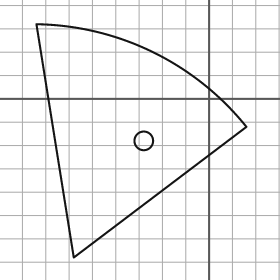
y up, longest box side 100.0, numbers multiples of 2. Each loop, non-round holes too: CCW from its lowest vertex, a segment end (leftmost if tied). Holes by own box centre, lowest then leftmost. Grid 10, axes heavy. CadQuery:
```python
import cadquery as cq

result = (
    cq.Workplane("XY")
    .moveTo(-58.0, -68.0)
    .lineTo(16.0, -12.0)
    .threePointArc((-24.0, 20.0), (-74.0, 32.0))
    .close()
    .moveTo(-28.0, -18.0)
    .circle(4.0)
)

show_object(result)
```